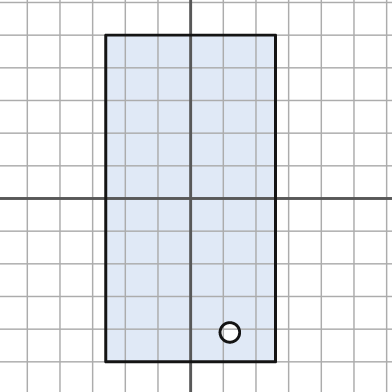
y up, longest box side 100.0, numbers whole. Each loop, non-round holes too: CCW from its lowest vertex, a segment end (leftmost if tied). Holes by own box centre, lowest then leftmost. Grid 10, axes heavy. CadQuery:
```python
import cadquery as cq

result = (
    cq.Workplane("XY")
    .moveTo(-26.0, -50.0)
    .lineTo(26.0, -50.0)
    .lineTo(26.0, 50.0)
    .lineTo(-26.0, 50.0)
    .close()
    .moveTo(12.0, -41.0)
    .circle(3.0)
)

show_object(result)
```